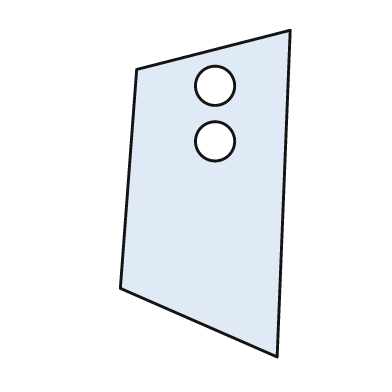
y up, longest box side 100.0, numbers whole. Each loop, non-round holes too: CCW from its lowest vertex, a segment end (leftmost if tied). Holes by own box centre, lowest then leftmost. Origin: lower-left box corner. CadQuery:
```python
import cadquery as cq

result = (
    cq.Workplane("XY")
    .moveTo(48.0, 0.0)
    .lineTo(52.0, 100.0)
    .lineTo(5.0, 88.0)
    .lineTo(0.0, 21.0)
    .close()
    .moveTo(29.0, 66.0)
    .circle(6.0)
    .moveTo(29.0, 83.0)
    .circle(6.0)
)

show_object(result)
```